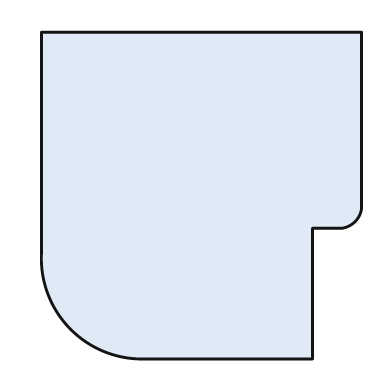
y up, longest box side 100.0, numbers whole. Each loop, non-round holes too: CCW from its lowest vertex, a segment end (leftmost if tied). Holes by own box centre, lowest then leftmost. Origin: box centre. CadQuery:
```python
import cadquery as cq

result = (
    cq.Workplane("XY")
    .moveTo(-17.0, -50.0)
    .lineTo(34.0, -50.0)
    .lineTo(34.0, -10.0)
    .lineTo(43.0, -10.0)
    .threePointArc((47.0, -8.0), (49.0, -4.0))
    .lineTo(49.0, 50.0)
    .lineTo(-49.0, 50.0)
    .lineTo(-49.0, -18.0)
    .threePointArc((-40.0, -41.0), (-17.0, -50.0))
    .close()
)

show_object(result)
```